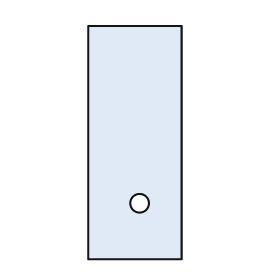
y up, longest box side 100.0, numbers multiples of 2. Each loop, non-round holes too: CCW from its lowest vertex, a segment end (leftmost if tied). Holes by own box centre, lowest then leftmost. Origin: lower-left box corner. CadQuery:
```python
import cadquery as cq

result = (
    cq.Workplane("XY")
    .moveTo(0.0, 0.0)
    .lineTo(40.0, 0.0)
    .lineTo(40.0, 100.0)
    .lineTo(0.0, 100.0)
    .close()
    .moveTo(22.0, 24.0)
    .circle(4.0)
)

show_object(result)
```